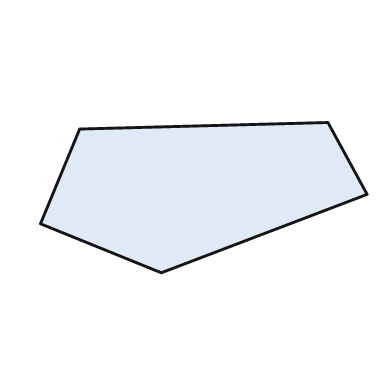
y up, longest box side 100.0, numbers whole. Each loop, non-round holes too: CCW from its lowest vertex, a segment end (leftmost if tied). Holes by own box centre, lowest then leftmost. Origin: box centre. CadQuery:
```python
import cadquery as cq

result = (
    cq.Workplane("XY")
    .moveTo(-13.0, -23.0)
    .lineTo(50.0, 1.0)
    .lineTo(38.0, 23.0)
    .lineTo(-38.0, 21.0)
    .lineTo(-50.0, -8.0)
    .close()
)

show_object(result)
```